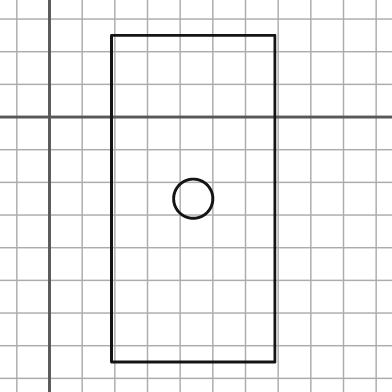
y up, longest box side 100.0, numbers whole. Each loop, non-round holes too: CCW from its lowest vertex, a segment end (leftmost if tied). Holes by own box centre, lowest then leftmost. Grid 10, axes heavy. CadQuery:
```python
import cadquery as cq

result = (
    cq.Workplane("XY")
    .moveTo(19.0, -75.0)
    .lineTo(69.0, -75.0)
    .lineTo(69.0, 25.0)
    .lineTo(19.0, 25.0)
    .close()
    .moveTo(44.0, -25.0)
    .circle(6.0)
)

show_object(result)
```